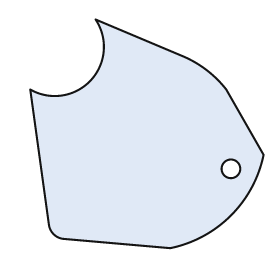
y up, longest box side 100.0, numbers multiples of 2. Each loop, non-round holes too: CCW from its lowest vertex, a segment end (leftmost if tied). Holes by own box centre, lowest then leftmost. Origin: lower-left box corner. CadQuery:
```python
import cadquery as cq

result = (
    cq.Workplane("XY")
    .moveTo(60.0, 0.0)
    .threePointArc((86.0, 14.0), (100.0, 40.0))
    .lineTo(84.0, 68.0)
    .threePointArc((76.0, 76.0), (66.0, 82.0))
    .lineTo(28.0, 98.0)
    .threePointArc((26.0, 72.0), (0.0, 68.0))
    .lineTo(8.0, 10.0)
    .threePointArc((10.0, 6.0), (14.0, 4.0))
    .close()
    .moveTo(86.0, 34.0)
    .circle(4.0)
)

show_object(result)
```